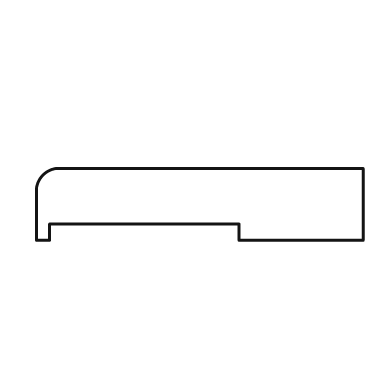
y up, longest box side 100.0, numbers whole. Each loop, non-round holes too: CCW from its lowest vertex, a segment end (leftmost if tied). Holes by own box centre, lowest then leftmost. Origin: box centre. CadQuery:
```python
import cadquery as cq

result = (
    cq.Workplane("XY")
    .moveTo(-50.0, -11.0)
    .lineTo(-46.0, -11.0)
    .lineTo(-46.0, -6.0)
    .lineTo(12.0, -6.0)
    .lineTo(12.0, -11.0)
    .lineTo(50.0, -11.0)
    .lineTo(50.0, 11.0)
    .lineTo(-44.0, 11.0)
    .threePointArc((-48.0, 9.0), (-50.0, 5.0))
    .close()
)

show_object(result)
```